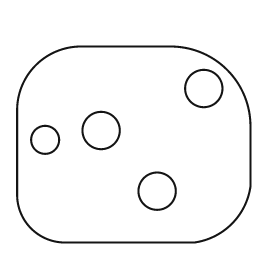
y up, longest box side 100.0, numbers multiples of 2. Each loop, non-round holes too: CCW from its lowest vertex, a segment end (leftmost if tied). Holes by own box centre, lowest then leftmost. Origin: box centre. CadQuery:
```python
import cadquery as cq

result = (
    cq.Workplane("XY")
    .moveTo(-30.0, -42.0)
    .lineTo(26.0, -42.0)
    .threePointArc((42.0, -34.0), (50.0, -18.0))
    .lineTo(50.0, 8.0)
    .threePointArc((40.0, 32.0), (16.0, 42.0))
    .lineTo(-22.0, 42.0)
    .threePointArc((-42.0, 34.0), (-50.0, 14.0))
    .lineTo(-50.0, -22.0)
    .threePointArc((-44.0, -36.0), (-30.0, -42.0))
    .close()
    .moveTo(10.0, -20.0)
    .circle(8.0)
    .moveTo(-38.0, 2.0)
    .circle(6.0)
    .moveTo(-14.0, 6.0)
    .circle(8.0)
    .moveTo(30.0, 24.0)
    .circle(8.0)
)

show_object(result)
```